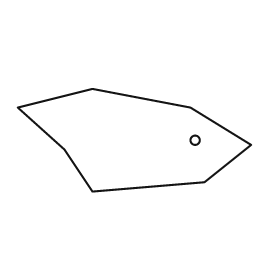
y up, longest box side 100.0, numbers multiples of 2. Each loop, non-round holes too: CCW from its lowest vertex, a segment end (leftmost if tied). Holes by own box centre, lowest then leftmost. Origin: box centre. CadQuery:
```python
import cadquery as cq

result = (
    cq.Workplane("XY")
    .moveTo(-18.0, -22.0)
    .lineTo(30.0, -18.0)
    .lineTo(50.0, -2.0)
    .lineTo(24.0, 14.0)
    .lineTo(-18.0, 22.0)
    .lineTo(-50.0, 14.0)
    .lineTo(-30.0, -4.0)
    .close()
    .moveTo(26.0, 0.0)
    .circle(2.0)
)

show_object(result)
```